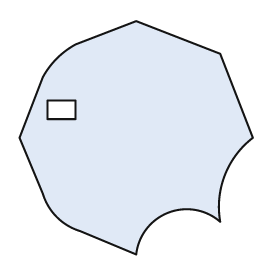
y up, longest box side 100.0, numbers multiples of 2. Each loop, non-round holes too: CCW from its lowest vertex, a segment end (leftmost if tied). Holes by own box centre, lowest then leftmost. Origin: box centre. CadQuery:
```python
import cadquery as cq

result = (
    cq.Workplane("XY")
    .moveTo(0.0, -50.0)
    .threePointArc((14.0, -32.0), (36.0, -36.0))
    .threePointArc((38.0, -16.0), (50.0, 0.0))
    .lineTo(36.0, 36.0)
    .lineTo(0.0, 50.0)
    .lineTo(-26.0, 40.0)
    .threePointArc((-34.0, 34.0), (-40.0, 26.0))
    .lineTo(-50.0, 0.0)
    .lineTo(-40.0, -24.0)
    .threePointArc((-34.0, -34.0), (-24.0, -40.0))
    .close()
    .moveTo(-38.0, 8.0)
    .lineTo(-26.0, 8.0)
    .lineTo(-26.0, 16.0)
    .lineTo(-38.0, 16.0)
    .close()
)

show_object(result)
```